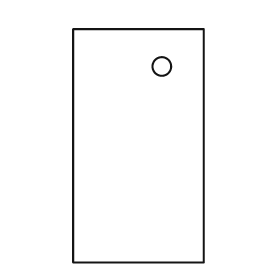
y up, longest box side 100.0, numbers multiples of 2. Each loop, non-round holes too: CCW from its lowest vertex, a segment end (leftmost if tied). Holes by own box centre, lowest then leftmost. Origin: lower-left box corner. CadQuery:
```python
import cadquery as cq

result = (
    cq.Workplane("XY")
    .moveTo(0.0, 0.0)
    .lineTo(56.0, 0.0)
    .lineTo(56.0, 100.0)
    .lineTo(0.0, 100.0)
    .close()
    .moveTo(38.0, 84.0)
    .circle(4.0)
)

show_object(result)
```